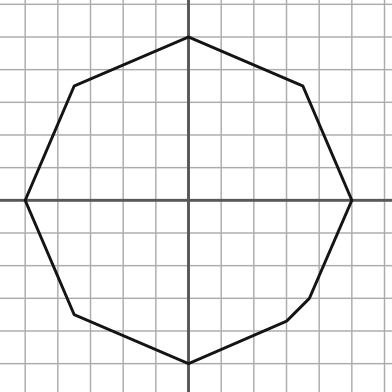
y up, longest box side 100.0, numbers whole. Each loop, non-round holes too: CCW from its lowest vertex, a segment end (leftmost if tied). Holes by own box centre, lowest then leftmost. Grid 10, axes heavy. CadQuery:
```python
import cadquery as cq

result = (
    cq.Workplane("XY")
    .moveTo(0.0, -50.0)
    .lineTo(30.0, -37.0)
    .lineTo(37.0, -30.0)
    .lineTo(50.0, 0.0)
    .lineTo(35.0, 35.0)
    .lineTo(0.0, 50.0)
    .lineTo(-35.0, 35.0)
    .lineTo(-50.0, 0.0)
    .lineTo(-35.0, -35.0)
    .close()
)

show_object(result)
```